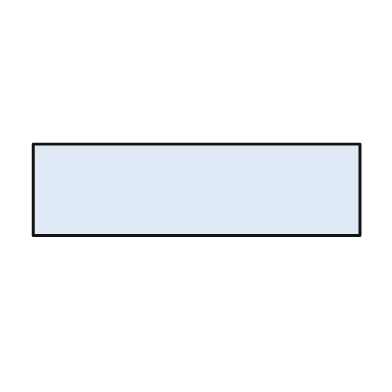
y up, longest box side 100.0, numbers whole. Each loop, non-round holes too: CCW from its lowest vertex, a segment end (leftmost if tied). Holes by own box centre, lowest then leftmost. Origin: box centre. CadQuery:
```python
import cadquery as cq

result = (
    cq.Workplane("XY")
    .moveTo(-50.0, -14.0)
    .lineTo(50.0, -14.0)
    .lineTo(50.0, 14.0)
    .lineTo(-50.0, 14.0)
    .close()
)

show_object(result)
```